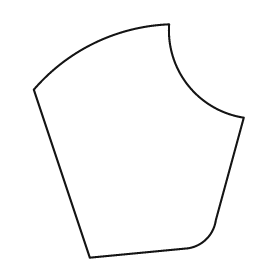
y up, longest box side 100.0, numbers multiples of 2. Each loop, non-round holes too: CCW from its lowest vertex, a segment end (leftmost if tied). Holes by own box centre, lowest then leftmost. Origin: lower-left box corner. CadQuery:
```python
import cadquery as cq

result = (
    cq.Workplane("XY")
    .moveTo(24.0, 0.0)
    .lineTo(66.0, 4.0)
    .threePointArc((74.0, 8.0), (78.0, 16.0))
    .lineTo(90.0, 60.0)
    .threePointArc((66.0, 74.0), (58.0, 100.0))
    .threePointArc((26.0, 92.0), (0.0, 72.0))
    .close()
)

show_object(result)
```